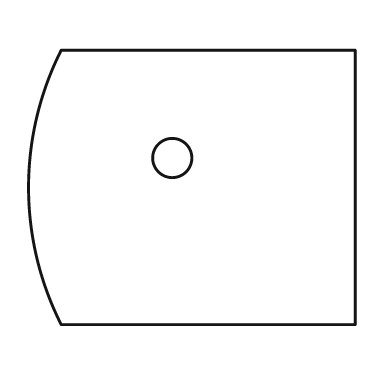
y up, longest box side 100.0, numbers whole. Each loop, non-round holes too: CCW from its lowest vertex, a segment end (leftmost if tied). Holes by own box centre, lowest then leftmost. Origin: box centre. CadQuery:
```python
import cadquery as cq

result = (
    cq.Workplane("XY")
    .moveTo(-40.0, -42.0)
    .lineTo(50.0, -42.0)
    .lineTo(50.0, 42.0)
    .lineTo(-40.0, 42.0)
    .threePointArc((-50.0, 0.0), (-40.0, -42.0))
    .close()
    .moveTo(-6.0, 9.0)
    .circle(6.0)
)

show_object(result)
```